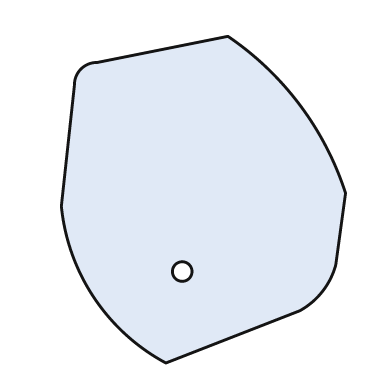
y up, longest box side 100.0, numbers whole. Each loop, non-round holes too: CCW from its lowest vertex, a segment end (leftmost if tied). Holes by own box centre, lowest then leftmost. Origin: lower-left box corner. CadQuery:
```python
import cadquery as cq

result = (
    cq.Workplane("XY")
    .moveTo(32.0, 0.0)
    .lineTo(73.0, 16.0)
    .threePointArc((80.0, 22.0), (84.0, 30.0))
    .lineTo(87.0, 52.0)
    .threePointArc((73.0, 79.0), (51.0, 100.0))
    .lineTo(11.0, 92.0)
    .threePointArc((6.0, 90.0), (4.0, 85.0))
    .lineTo(0.0, 48.0)
    .threePointArc((10.0, 20.0), (32.0, 0.0))
    .close()
    .moveTo(37.0, 28.0)
    .circle(3.0)
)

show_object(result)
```